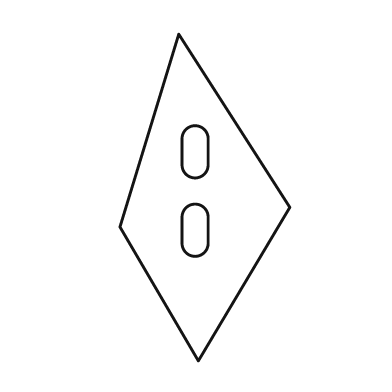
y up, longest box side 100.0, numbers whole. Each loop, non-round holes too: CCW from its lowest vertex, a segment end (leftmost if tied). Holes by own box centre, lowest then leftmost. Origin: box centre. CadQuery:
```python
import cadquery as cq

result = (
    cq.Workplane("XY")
    .moveTo(-2.0, -50.0)
    .lineTo(26.0, -3.0)
    .lineTo(-8.0, 50.0)
    .lineTo(-26.0, -9.0)
    .close()
    .moveTo(-7.0, -14.0)
    .threePointArc((-3.0, -18.0), (1.0, -14.0))
    .lineTo(1.0, -6.0)
    .threePointArc((-3.0, -2.0), (-7.0, -6.0))
    .close()
    .moveTo(-7.0, 10.0)
    .threePointArc((-3.0, 6.0), (1.0, 10.0))
    .lineTo(1.0, 18.0)
    .threePointArc((-3.0, 22.0), (-7.0, 18.0))
    .close()
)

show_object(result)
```